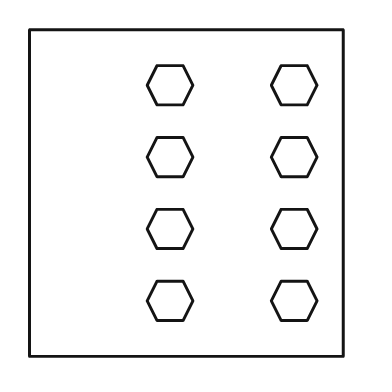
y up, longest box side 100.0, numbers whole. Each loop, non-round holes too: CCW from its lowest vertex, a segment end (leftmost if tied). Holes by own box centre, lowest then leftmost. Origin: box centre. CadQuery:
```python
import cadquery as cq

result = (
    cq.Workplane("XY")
    .moveTo(-48.0, -50.0)
    .lineTo(48.0, -50.0)
    .lineTo(48.0, 50.0)
    .lineTo(-48.0, 50.0)
    .close()
    .moveTo(-9.0, -39.0)
    .lineTo(-1.0, -39.0)
    .lineTo(2.0, -33.0)
    .lineTo(-1.0, -27.0)
    .lineTo(-9.0, -27.0)
    .lineTo(-12.0, -33.0)
    .close()
    .moveTo(29.0, -39.0)
    .lineTo(37.0, -39.0)
    .lineTo(40.0, -33.0)
    .lineTo(37.0, -27.0)
    .lineTo(29.0, -27.0)
    .lineTo(26.0, -33.0)
    .close()
    .moveTo(-9.0, -17.0)
    .lineTo(-1.0, -17.0)
    .lineTo(2.0, -11.0)
    .lineTo(-1.0, -5.0)
    .lineTo(-9.0, -5.0)
    .lineTo(-12.0, -11.0)
    .close()
    .moveTo(29.0, -17.0)
    .lineTo(37.0, -17.0)
    .lineTo(40.0, -11.0)
    .lineTo(37.0, -5.0)
    .lineTo(29.0, -5.0)
    .lineTo(26.0, -11.0)
    .close()
    .moveTo(-9.0, 5.0)
    .lineTo(-1.0, 5.0)
    .lineTo(2.0, 11.0)
    .lineTo(-1.0, 17.0)
    .lineTo(-9.0, 17.0)
    .lineTo(-12.0, 11.0)
    .close()
    .moveTo(29.0, 5.0)
    .lineTo(37.0, 5.0)
    .lineTo(40.0, 11.0)
    .lineTo(37.0, 17.0)
    .lineTo(29.0, 17.0)
    .lineTo(26.0, 11.0)
    .close()
    .moveTo(-9.0, 27.0)
    .lineTo(-1.0, 27.0)
    .lineTo(2.0, 33.0)
    .lineTo(-1.0, 39.0)
    .lineTo(-9.0, 39.0)
    .lineTo(-12.0, 33.0)
    .close()
    .moveTo(29.0, 27.0)
    .lineTo(37.0, 27.0)
    .lineTo(40.0, 33.0)
    .lineTo(37.0, 39.0)
    .lineTo(29.0, 39.0)
    .lineTo(26.0, 33.0)
    .close()
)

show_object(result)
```